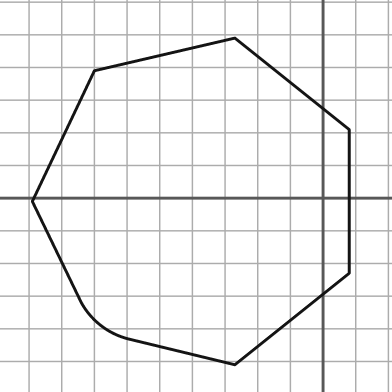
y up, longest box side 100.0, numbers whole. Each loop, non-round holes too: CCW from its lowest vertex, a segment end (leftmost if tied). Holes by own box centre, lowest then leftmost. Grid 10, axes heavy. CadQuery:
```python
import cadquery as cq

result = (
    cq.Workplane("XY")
    .moveTo(-27.0, -51.0)
    .lineTo(8.0, -23.0)
    .lineTo(8.0, 21.0)
    .lineTo(-27.0, 49.0)
    .lineTo(-70.0, 39.0)
    .lineTo(-89.0, -1.0)
    .lineTo(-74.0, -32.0)
    .threePointArc((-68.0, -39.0), (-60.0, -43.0))
    .close()
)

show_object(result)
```